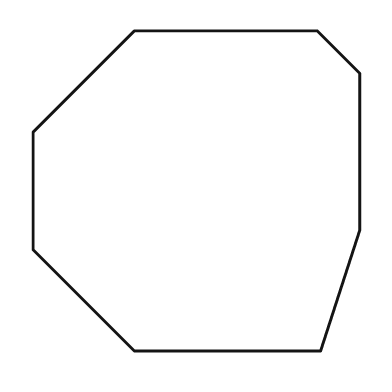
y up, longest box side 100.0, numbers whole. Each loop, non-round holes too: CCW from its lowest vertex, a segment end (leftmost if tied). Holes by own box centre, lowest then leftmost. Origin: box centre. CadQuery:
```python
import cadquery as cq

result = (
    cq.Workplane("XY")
    .moveTo(-19.0, -49.0)
    .lineTo(38.0, -49.0)
    .lineTo(50.0, -12.0)
    .lineTo(50.0, 36.0)
    .lineTo(37.0, 49.0)
    .lineTo(-19.0, 49.0)
    .lineTo(-50.0, 18.0)
    .lineTo(-50.0, -18.0)
    .close()
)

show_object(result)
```